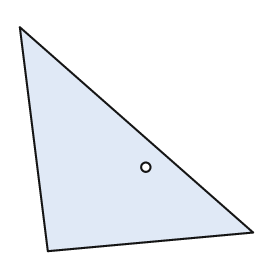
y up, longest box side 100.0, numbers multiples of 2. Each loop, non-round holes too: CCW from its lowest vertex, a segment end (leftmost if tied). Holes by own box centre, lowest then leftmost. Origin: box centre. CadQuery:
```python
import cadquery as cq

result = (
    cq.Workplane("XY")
    .moveTo(-38.0, -48.0)
    .lineTo(50.0, -40.0)
    .lineTo(-50.0, 48.0)
    .close()
    .moveTo(4.0, -12.0)
    .circle(2.0)
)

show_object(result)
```